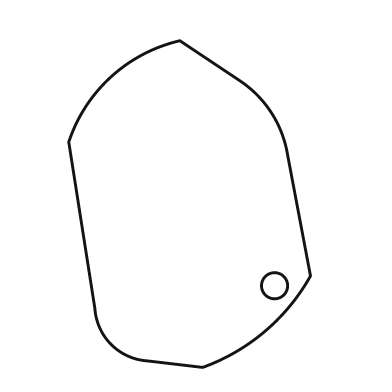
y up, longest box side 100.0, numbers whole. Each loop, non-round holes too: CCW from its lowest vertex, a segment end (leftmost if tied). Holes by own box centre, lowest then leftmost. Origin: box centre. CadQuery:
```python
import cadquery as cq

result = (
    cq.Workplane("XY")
    .moveTo(4.0, -50.0)
    .threePointArc((23.0, -39.0), (37.0, -22.0))
    .lineTo(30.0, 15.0)
    .threePointArc((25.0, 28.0), (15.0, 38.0))
    .lineTo(-3.0, 50.0)
    .threePointArc((-24.0, 39.0), (-37.0, 19.0))
    .lineTo(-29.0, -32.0)
    .threePointArc((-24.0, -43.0), (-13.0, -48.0))
    .close()
    .moveTo(26.0, -25.0)
    .circle(4.0)
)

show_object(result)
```